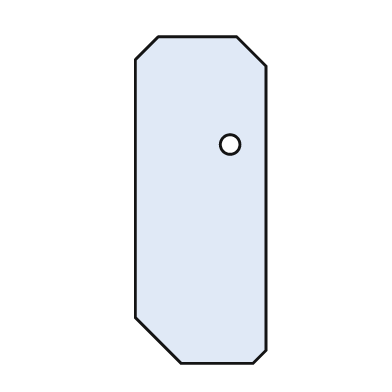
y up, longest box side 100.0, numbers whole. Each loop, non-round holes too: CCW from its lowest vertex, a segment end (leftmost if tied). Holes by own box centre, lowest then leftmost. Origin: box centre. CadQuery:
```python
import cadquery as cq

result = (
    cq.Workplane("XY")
    .moveTo(-6.0, -50.0)
    .lineTo(16.0, -50.0)
    .lineTo(20.0, -46.0)
    .lineTo(20.0, 41.0)
    .lineTo(11.0, 50.0)
    .lineTo(-13.0, 50.0)
    .lineTo(-20.0, 43.0)
    .lineTo(-20.0, -36.0)
    .close()
    .moveTo(9.0, 17.0)
    .circle(3.0)
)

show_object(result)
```